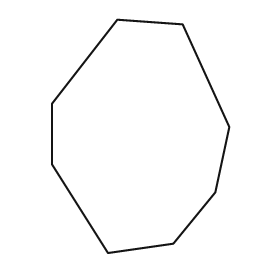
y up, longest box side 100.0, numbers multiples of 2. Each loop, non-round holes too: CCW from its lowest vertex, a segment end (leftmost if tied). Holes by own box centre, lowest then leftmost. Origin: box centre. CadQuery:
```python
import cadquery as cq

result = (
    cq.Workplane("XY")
    .moveTo(-14.0, -50.0)
    .lineTo(14.0, -46.0)
    .lineTo(32.0, -24.0)
    .lineTo(38.0, 4.0)
    .lineTo(18.0, 48.0)
    .lineTo(-10.0, 50.0)
    .lineTo(-38.0, 14.0)
    .lineTo(-38.0, -12.0)
    .close()
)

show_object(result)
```